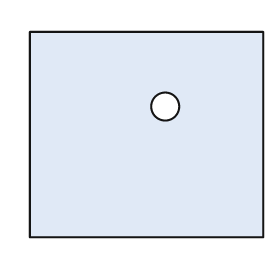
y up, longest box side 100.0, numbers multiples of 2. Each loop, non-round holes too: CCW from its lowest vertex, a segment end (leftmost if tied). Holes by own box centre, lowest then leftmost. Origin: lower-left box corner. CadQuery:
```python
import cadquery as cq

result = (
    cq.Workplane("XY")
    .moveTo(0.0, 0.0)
    .lineTo(100.0, 0.0)
    .lineTo(100.0, 88.0)
    .lineTo(0.0, 88.0)
    .close()
    .moveTo(58.0, 56.0)
    .circle(6.0)
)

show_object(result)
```